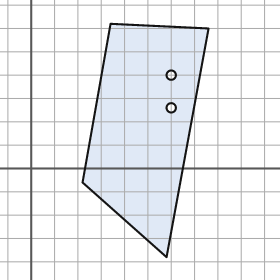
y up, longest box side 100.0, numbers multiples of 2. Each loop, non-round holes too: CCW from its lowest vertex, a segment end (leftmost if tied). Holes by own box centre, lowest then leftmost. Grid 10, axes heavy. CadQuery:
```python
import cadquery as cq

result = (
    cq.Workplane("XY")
    .moveTo(58.0, -38.0)
    .lineTo(76.0, 60.0)
    .lineTo(34.0, 62.0)
    .lineTo(22.0, -6.0)
    .close()
    .moveTo(60.0, 26.0)
    .circle(2.0)
    .moveTo(60.0, 40.0)
    .circle(2.0)
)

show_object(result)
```